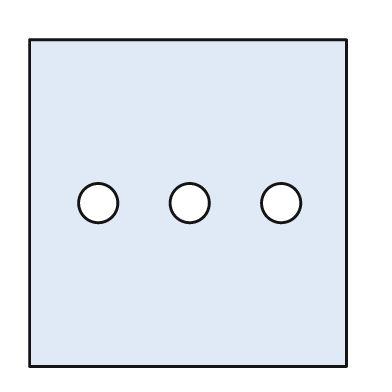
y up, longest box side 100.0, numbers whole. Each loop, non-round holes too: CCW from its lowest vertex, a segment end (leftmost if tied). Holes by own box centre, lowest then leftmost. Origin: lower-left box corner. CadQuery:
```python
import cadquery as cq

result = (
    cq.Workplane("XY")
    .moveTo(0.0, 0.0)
    .lineTo(97.0, 0.0)
    .lineTo(97.0, 100.0)
    .lineTo(0.0, 100.0)
    .close()
    .moveTo(21.0, 50.0)
    .circle(6.0)
    .moveTo(49.0, 50.0)
    .circle(6.0)
    .moveTo(77.0, 50.0)
    .circle(6.0)
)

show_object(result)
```